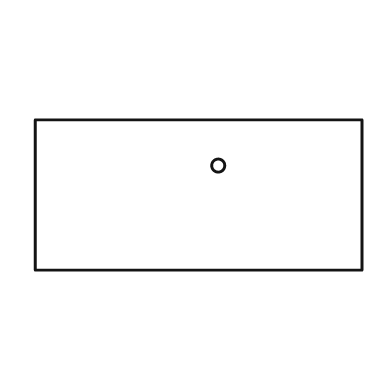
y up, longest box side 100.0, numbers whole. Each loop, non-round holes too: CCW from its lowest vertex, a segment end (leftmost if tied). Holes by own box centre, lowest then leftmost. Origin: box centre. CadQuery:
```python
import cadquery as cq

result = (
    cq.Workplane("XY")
    .moveTo(-50.0, -23.0)
    .lineTo(50.0, -23.0)
    .lineTo(50.0, 23.0)
    .lineTo(-50.0, 23.0)
    .close()
    .moveTo(6.0, 9.0)
    .circle(2.0)
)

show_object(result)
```